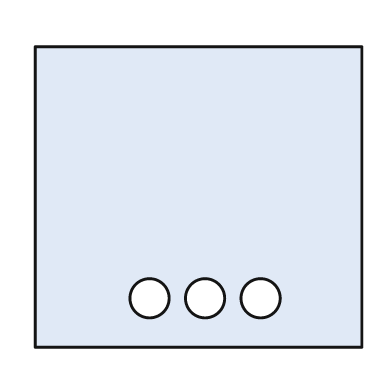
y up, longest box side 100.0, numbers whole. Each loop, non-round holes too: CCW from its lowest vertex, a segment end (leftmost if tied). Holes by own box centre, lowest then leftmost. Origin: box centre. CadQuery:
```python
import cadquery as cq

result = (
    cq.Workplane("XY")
    .moveTo(-50.0, -46.0)
    .lineTo(50.0, -46.0)
    .lineTo(50.0, 46.0)
    .lineTo(-50.0, 46.0)
    .close()
    .moveTo(-15.0, -31.0)
    .circle(6.0)
    .moveTo(2.0, -31.0)
    .circle(6.0)
    .moveTo(19.0, -31.0)
    .circle(6.0)
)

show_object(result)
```